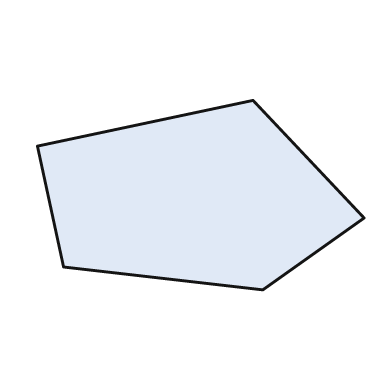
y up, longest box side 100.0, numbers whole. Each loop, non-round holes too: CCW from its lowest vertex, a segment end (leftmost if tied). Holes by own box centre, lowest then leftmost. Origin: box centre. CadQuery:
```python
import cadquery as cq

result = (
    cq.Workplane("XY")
    .moveTo(19.0, -29.0)
    .lineTo(50.0, -7.0)
    .lineTo(16.0, 29.0)
    .lineTo(-50.0, 15.0)
    .lineTo(-42.0, -22.0)
    .close()
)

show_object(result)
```